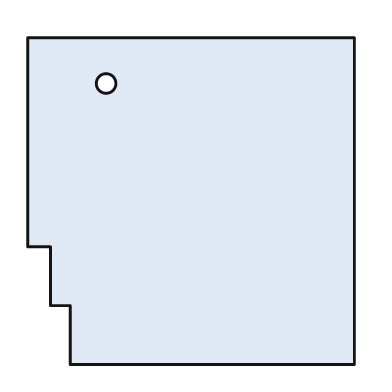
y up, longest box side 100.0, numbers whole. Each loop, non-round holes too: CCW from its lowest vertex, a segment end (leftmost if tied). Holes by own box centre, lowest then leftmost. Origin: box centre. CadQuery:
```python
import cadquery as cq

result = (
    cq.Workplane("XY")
    .moveTo(-37.0, -50.0)
    .lineTo(50.0, -50.0)
    .lineTo(50.0, 50.0)
    .lineTo(-50.0, 50.0)
    .lineTo(-50.0, -14.0)
    .lineTo(-43.0, -14.0)
    .lineTo(-43.0, -32.0)
    .lineTo(-37.0, -32.0)
    .close()
    .moveTo(-26.0, 36.0)
    .circle(3.0)
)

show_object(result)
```